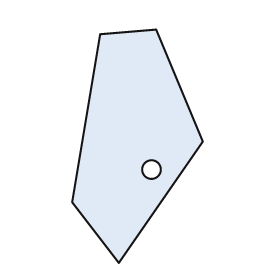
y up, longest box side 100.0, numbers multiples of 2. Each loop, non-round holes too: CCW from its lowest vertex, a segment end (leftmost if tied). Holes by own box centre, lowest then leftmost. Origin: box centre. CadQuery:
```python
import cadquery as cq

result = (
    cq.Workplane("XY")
    .moveTo(-8.0, -50.0)
    .lineTo(28.0, 2.0)
    .lineTo(8.0, 50.0)
    .lineTo(-16.0, 48.0)
    .lineTo(-28.0, -24.0)
    .close()
    .moveTo(6.0, -10.0)
    .circle(4.0)
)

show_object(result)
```